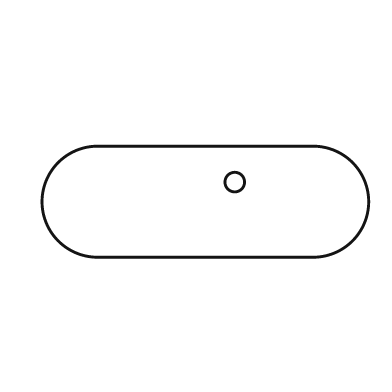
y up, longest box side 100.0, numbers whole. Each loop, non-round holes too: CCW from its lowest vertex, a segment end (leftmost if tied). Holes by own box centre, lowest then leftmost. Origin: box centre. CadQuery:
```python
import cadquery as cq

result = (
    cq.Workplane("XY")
    .moveTo(-33.0, -17.0)
    .lineTo(33.0, -17.0)
    .threePointArc((50.0, 0.0), (33.0, 17.0))
    .lineTo(-33.0, 17.0)
    .threePointArc((-50.0, 0.0), (-33.0, -17.0))
    .close()
    .moveTo(9.0, 6.0)
    .circle(3.0)
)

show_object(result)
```